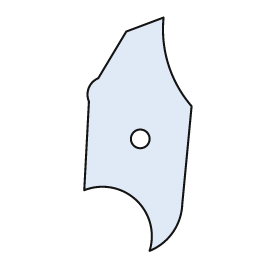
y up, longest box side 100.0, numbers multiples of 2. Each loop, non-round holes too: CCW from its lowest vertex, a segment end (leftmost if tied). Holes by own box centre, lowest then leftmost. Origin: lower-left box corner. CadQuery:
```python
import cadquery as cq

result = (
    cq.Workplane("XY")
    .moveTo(28.0, 0.0)
    .threePointArc((38.0, 8.0), (42.0, 20.0))
    .lineTo(46.0, 62.0)
    .threePointArc((36.0, 80.0), (34.0, 100.0))
    .lineTo(18.0, 94.0)
    .lineTo(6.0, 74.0)
    .threePointArc((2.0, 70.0), (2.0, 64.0))
    .lineTo(0.0, 26.0)
    .threePointArc((22.0, 22.0), (28.0, 0.0))
    .close()
    .moveTo(24.0, 48.0)
    .circle(4.0)
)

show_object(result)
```